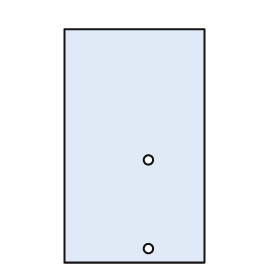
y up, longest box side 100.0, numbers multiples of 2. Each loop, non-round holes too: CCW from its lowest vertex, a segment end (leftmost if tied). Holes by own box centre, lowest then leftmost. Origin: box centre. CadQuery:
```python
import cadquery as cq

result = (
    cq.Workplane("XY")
    .moveTo(-30.0, -50.0)
    .lineTo(30.0, -50.0)
    .lineTo(30.0, 50.0)
    .lineTo(-30.0, 50.0)
    .close()
    .moveTo(6.0, -44.0)
    .circle(2.0)
    .moveTo(6.0, -6.0)
    .circle(2.0)
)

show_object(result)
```